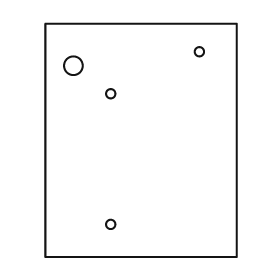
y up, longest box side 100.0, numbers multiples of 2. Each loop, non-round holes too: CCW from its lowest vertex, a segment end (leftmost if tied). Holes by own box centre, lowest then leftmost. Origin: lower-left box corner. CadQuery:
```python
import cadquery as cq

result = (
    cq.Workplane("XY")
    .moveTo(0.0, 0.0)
    .lineTo(82.0, 0.0)
    .lineTo(82.0, 100.0)
    .lineTo(0.0, 100.0)
    .close()
    .moveTo(28.0, 14.0)
    .circle(2.0)
    .moveTo(28.0, 70.0)
    .circle(2.0)
    .moveTo(12.0, 82.0)
    .circle(4.0)
    .moveTo(66.0, 88.0)
    .circle(2.0)
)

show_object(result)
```